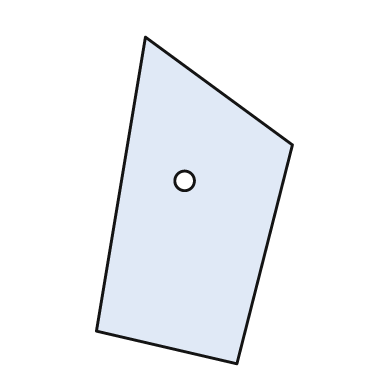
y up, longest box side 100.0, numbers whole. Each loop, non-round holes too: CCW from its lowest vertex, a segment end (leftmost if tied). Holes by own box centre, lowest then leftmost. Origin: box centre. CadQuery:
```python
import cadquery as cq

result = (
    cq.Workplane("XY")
    .moveTo(13.0, -50.0)
    .lineTo(30.0, 17.0)
    .lineTo(-15.0, 50.0)
    .lineTo(-30.0, -40.0)
    .close()
    .moveTo(-3.0, 6.0)
    .circle(3.0)
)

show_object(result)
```